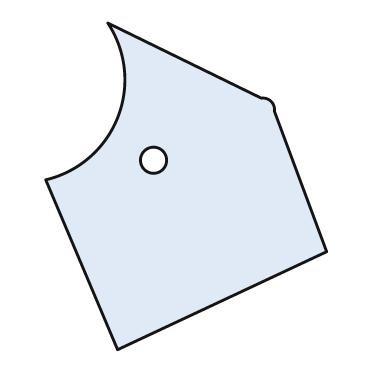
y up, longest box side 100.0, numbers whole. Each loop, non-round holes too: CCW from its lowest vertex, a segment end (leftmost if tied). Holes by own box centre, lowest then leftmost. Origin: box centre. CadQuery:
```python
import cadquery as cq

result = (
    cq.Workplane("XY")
    .moveTo(-21.0, -50.0)
    .lineTo(43.0, -20.0)
    .lineTo(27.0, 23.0)
    .threePointArc((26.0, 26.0), (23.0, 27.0))
    .lineTo(-24.0, 50.0)
    .threePointArc((-21.0, 21.0), (-43.0, 2.0))
    .close()
    .moveTo(-10.0, 8.0)
    .circle(4.0)
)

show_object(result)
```